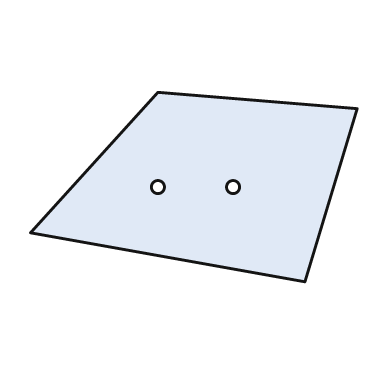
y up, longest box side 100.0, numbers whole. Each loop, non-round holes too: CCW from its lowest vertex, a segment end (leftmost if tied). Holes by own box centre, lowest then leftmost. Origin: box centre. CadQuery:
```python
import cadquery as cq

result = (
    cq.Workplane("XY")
    .moveTo(34.0, -29.0)
    .lineTo(50.0, 24.0)
    .lineTo(-11.0, 29.0)
    .lineTo(-50.0, -14.0)
    .close()
    .moveTo(-11.0, 0.0)
    .circle(2.0)
    .moveTo(12.0, 0.0)
    .circle(2.0)
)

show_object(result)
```